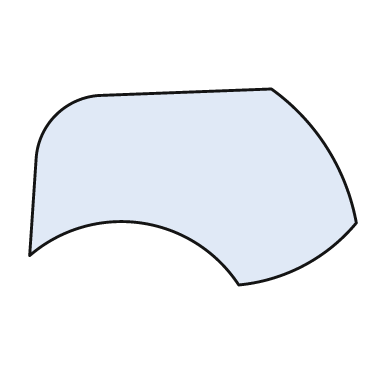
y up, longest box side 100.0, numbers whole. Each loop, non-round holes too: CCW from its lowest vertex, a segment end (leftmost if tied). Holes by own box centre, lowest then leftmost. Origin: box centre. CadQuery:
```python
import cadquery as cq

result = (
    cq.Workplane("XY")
    .moveTo(14.0, -30.0)
    .threePointArc((34.0, -24.0), (50.0, -11.0))
    .threePointArc((41.0, 12.0), (24.0, 30.0))
    .lineTo(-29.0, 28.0)
    .threePointArc((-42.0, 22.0), (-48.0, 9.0))
    .lineTo(-50.0, -21.0)
    .threePointArc((-16.0, -11.0), (14.0, -30.0))
    .close()
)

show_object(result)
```